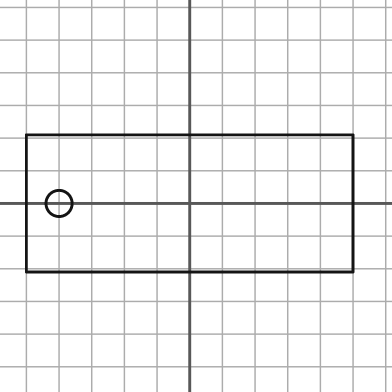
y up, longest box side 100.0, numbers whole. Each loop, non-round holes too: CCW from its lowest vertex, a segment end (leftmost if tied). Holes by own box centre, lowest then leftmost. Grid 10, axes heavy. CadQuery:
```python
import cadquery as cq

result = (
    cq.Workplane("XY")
    .moveTo(-50.0, -21.0)
    .lineTo(50.0, -21.0)
    .lineTo(50.0, 21.0)
    .lineTo(-50.0, 21.0)
    .close()
    .moveTo(-40.0, 0.0)
    .circle(4.0)
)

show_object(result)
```